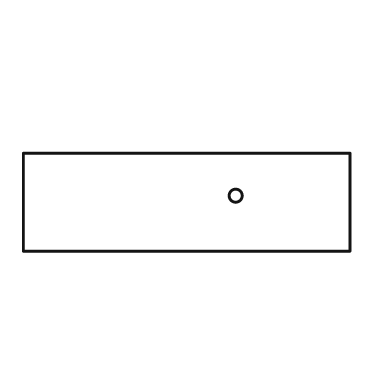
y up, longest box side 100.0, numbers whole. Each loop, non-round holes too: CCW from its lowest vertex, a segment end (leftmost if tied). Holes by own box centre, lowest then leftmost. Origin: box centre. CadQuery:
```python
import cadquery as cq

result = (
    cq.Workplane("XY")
    .moveTo(-50.0, -15.0)
    .lineTo(50.0, -15.0)
    .lineTo(50.0, 15.0)
    .lineTo(-50.0, 15.0)
    .close()
    .moveTo(15.0, 2.0)
    .circle(2.0)
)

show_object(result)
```